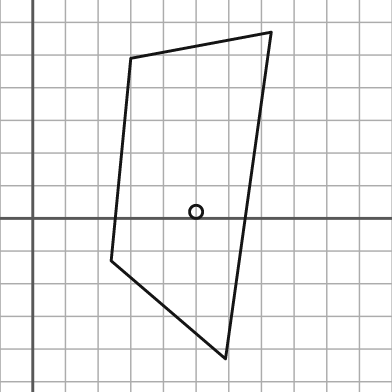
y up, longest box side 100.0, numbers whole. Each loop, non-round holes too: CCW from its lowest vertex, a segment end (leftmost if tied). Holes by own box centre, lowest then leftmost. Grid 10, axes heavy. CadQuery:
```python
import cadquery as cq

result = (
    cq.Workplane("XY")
    .moveTo(59.0, -43.0)
    .lineTo(73.0, 57.0)
    .lineTo(30.0, 49.0)
    .lineTo(24.0, -13.0)
    .close()
    .moveTo(50.0, 2.0)
    .circle(2.0)
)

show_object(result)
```